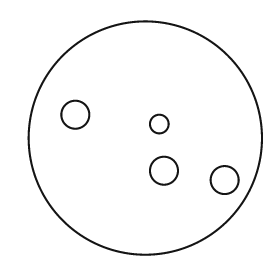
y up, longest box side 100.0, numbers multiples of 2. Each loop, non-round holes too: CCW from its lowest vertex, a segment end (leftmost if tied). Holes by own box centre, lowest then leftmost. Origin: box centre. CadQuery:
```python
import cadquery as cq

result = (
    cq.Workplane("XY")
    .moveTo(0.0, 0.0)
    .circle(50.0)
    .moveTo(34.0, -18.0)
    .circle(6.0)
    .moveTo(8.0, -14.0)
    .circle(6.0)
    .moveTo(6.0, 6.0)
    .circle(4.0)
    .moveTo(-30.0, 10.0)
    .circle(6.0)
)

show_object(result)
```